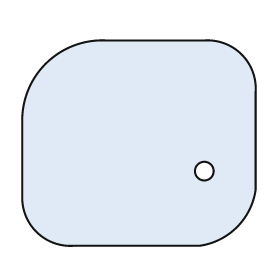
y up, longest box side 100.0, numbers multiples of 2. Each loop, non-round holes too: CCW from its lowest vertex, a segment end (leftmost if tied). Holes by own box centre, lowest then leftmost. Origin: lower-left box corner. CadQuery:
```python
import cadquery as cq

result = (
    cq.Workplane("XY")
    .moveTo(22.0, 0.0)
    .lineTo(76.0, 0.0)
    .threePointArc((92.0, 8.0), (100.0, 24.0))
    .lineTo(100.0, 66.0)
    .threePointArc((94.0, 82.0), (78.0, 88.0))
    .lineTo(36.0, 88.0)
    .threePointArc((10.0, 78.0), (0.0, 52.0))
    .lineTo(0.0, 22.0)
    .threePointArc((6.0, 6.0), (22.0, 0.0))
    .close()
    .moveTo(78.0, 32.0)
    .circle(4.0)
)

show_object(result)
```